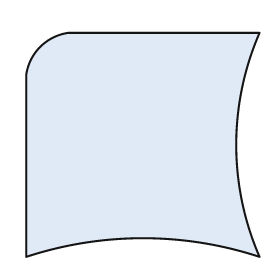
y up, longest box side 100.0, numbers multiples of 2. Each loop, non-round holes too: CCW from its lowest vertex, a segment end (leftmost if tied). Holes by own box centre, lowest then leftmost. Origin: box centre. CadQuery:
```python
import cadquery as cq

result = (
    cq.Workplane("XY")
    .moveTo(-50.0, -48.0)
    .threePointArc((0.0, -40.0), (50.0, -48.0))
    .threePointArc((40.0, 0.0), (50.0, 48.0))
    .lineTo(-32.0, 48.0)
    .threePointArc((-44.0, 42.0), (-50.0, 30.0))
    .close()
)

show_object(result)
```